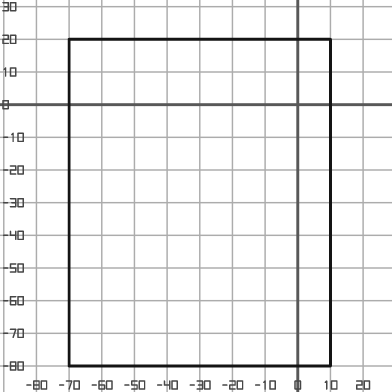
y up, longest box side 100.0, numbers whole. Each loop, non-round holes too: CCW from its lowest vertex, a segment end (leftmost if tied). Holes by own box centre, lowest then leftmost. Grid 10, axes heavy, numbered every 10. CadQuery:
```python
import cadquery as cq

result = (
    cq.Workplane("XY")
    .moveTo(-70.0, -80.0)
    .lineTo(10.0, -80.0)
    .lineTo(10.0, 20.0)
    .lineTo(-70.0, 20.0)
    .close()
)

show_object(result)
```